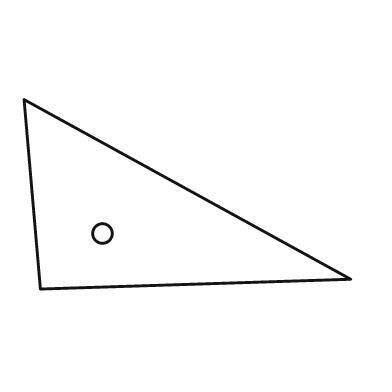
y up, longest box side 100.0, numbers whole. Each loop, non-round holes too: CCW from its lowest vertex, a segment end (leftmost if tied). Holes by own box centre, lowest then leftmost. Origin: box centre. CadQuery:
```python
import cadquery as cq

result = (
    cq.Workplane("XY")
    .moveTo(-45.0, -29.0)
    .lineTo(50.0, -26.0)
    .lineTo(-50.0, 29.0)
    .close()
    .moveTo(-26.0, -12.0)
    .circle(3.0)
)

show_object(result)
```